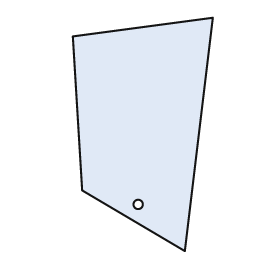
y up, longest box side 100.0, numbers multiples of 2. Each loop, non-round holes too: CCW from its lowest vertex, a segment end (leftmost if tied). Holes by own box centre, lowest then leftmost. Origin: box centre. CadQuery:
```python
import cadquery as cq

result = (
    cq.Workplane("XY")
    .moveTo(18.0, -50.0)
    .lineTo(30.0, 50.0)
    .lineTo(-30.0, 42.0)
    .lineTo(-26.0, -24.0)
    .close()
    .moveTo(-2.0, -30.0)
    .circle(2.0)
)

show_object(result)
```